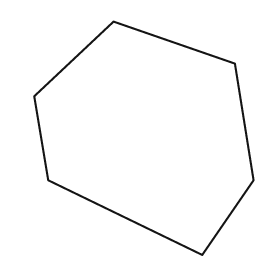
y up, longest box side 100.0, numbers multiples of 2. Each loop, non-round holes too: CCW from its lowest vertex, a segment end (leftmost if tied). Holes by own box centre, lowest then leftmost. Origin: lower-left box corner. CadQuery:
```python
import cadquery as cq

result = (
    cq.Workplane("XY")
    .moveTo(72.0, 0.0)
    .lineTo(94.0, 32.0)
    .lineTo(86.0, 82.0)
    .lineTo(34.0, 100.0)
    .lineTo(0.0, 68.0)
    .lineTo(6.0, 32.0)
    .close()
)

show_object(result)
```